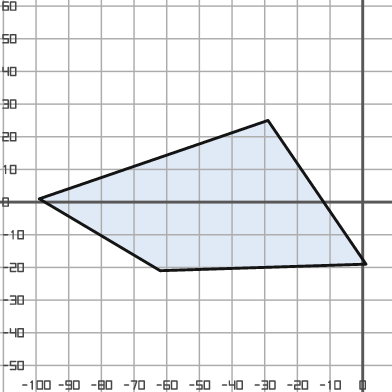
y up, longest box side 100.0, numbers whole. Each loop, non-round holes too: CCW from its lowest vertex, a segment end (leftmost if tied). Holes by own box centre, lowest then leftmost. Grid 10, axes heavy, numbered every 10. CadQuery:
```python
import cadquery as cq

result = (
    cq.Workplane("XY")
    .moveTo(-62.0, -21.0)
    .lineTo(1.0, -19.0)
    .lineTo(-29.0, 25.0)
    .lineTo(-99.0, 1.0)
    .close()
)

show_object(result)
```